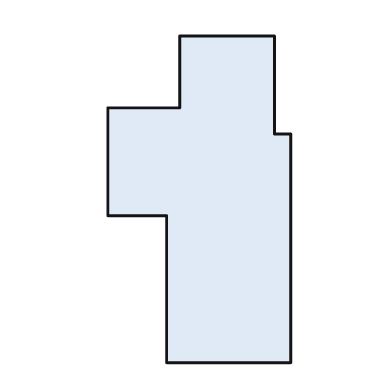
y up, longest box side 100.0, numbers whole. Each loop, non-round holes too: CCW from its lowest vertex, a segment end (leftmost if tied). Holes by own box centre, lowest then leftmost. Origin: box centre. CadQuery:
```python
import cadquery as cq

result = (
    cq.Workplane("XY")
    .moveTo(-10.0, -50.0)
    .lineTo(28.0, -50.0)
    .lineTo(28.0, 20.0)
    .lineTo(23.0, 20.0)
    .lineTo(23.0, 50.0)
    .lineTo(-6.0, 50.0)
    .lineTo(-6.0, 28.0)
    .lineTo(-28.0, 28.0)
    .lineTo(-28.0, -5.0)
    .lineTo(-10.0, -5.0)
    .close()
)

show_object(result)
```